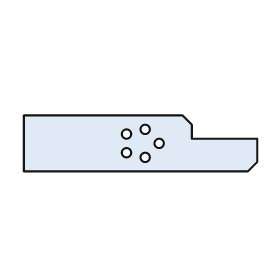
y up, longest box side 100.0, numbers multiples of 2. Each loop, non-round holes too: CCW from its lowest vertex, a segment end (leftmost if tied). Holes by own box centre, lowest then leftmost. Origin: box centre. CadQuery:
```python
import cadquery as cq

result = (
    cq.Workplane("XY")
    .moveTo(-50.0, -12.0)
    .lineTo(46.0, -12.0)
    .lineTo(50.0, -8.0)
    .lineTo(50.0, 2.0)
    .lineTo(22.0, 2.0)
    .lineTo(22.0, 8.0)
    .lineTo(18.0, 12.0)
    .lineTo(-50.0, 12.0)
    .close()
    .moveTo(2.0, -6.0)
    .circle(2.0)
    .moveTo(-6.0, -4.0)
    .circle(2.0)
    .moveTo(8.0, 0.0)
    .circle(2.0)
    .moveTo(-6.0, 4.0)
    .circle(2.0)
    .moveTo(2.0, 6.0)
    .circle(2.0)
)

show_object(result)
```